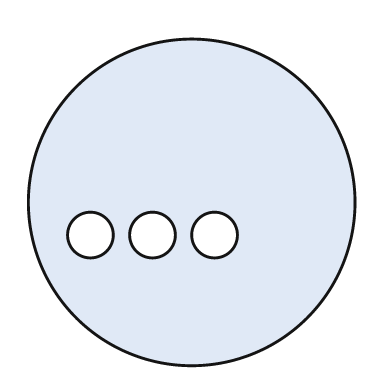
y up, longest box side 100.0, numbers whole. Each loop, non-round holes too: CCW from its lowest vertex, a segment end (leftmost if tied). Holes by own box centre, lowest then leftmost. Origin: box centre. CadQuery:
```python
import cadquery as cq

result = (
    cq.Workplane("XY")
    .moveTo(0.0, 0.0)
    .circle(50.0)
    .moveTo(-31.0, -10.0)
    .circle(7.0)
    .moveTo(-12.0, -10.0)
    .circle(7.0)
    .moveTo(7.0, -10.0)
    .circle(7.0)
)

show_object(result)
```